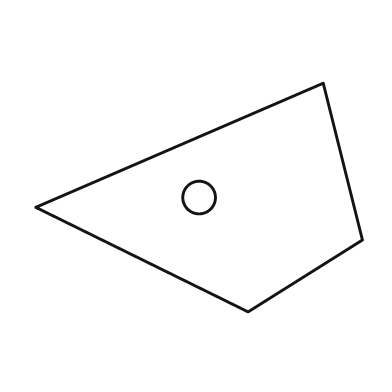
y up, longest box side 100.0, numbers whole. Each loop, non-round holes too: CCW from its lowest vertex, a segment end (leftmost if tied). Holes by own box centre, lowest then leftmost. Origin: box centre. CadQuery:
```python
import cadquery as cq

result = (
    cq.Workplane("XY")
    .moveTo(15.0, -35.0)
    .lineTo(50.0, -13.0)
    .lineTo(38.0, 35.0)
    .lineTo(-50.0, -3.0)
    .close()
    .moveTo(0.0, 0.0)
    .circle(5.0)
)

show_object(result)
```